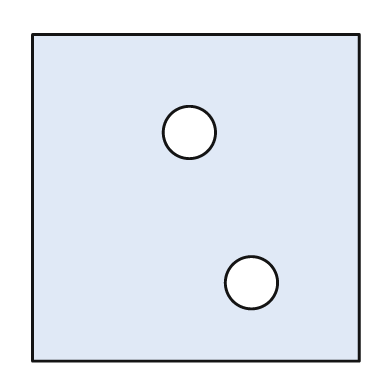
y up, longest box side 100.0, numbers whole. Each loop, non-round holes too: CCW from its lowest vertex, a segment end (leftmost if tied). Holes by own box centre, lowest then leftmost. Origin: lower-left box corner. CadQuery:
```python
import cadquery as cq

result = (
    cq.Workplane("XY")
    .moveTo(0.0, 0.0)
    .lineTo(100.0, 0.0)
    .lineTo(100.0, 100.0)
    .lineTo(0.0, 100.0)
    .close()
    .moveTo(67.0, 24.0)
    .circle(8.0)
    .moveTo(48.0, 70.0)
    .circle(8.0)
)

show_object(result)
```